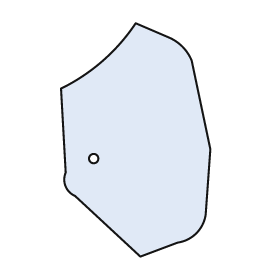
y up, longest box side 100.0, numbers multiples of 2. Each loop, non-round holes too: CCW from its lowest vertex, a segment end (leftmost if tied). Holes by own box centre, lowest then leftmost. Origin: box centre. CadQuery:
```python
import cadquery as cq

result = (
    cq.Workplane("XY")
    .moveTo(2.0, -50.0)
    .lineTo(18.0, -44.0)
    .threePointArc((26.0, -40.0), (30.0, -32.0))
    .lineTo(32.0, -4.0)
    .lineTo(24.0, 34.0)
    .threePointArc((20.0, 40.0), (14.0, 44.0))
    .lineTo(0.0, 50.0)
    .threePointArc((-14.0, 34.0), (-32.0, 22.0))
    .lineTo(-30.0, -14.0)
    .threePointArc((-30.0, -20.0), (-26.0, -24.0))
    .close()
    .moveTo(-18.0, -8.0)
    .circle(2.0)
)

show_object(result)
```